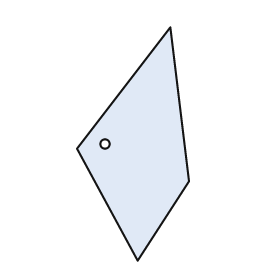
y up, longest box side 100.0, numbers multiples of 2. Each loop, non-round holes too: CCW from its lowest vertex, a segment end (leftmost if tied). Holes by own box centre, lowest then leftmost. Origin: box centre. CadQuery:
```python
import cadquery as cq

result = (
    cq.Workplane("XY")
    .moveTo(2.0, -50.0)
    .lineTo(24.0, -16.0)
    .lineTo(16.0, 50.0)
    .lineTo(-24.0, -2.0)
    .close()
    .moveTo(-12.0, 0.0)
    .circle(2.0)
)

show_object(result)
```